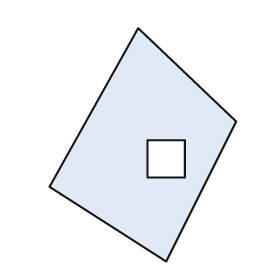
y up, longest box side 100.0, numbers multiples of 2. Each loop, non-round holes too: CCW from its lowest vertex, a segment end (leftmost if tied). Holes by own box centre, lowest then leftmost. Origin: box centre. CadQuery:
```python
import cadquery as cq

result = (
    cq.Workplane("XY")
    .moveTo(10.0, -50.0)
    .lineTo(40.0, 10.0)
    .lineTo(-2.0, 50.0)
    .lineTo(-40.0, -18.0)
    .close()
    .moveTo(2.0, -14.0)
    .lineTo(18.0, -14.0)
    .lineTo(18.0, 2.0)
    .lineTo(2.0, 2.0)
    .close()
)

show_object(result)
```